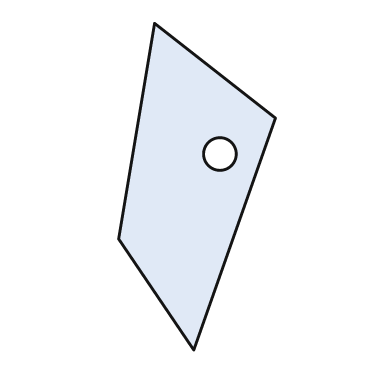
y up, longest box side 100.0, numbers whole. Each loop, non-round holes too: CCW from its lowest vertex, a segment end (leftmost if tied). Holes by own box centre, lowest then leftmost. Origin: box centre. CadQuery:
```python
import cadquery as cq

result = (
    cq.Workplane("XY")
    .moveTo(-1.0, -50.0)
    .lineTo(24.0, 21.0)
    .lineTo(-13.0, 50.0)
    .lineTo(-24.0, -16.0)
    .close()
    .moveTo(7.0, 10.0)
    .circle(5.0)
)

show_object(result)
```